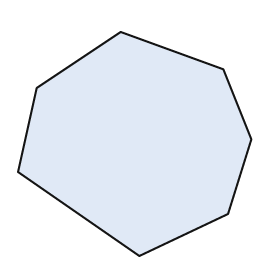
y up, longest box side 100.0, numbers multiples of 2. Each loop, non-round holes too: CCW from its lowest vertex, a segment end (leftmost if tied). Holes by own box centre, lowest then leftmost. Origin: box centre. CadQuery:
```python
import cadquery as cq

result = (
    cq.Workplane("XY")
    .moveTo(2.0, -48.0)
    .lineTo(40.0, -30.0)
    .lineTo(50.0, 2.0)
    .lineTo(38.0, 32.0)
    .lineTo(-6.0, 48.0)
    .lineTo(-42.0, 24.0)
    .lineTo(-50.0, -12.0)
    .close()
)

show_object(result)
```